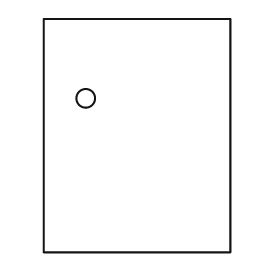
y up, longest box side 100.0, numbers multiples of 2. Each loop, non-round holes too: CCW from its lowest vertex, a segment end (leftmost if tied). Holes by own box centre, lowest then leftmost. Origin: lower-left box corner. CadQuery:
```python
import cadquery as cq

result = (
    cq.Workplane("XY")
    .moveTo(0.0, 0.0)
    .lineTo(80.0, 0.0)
    .lineTo(80.0, 100.0)
    .lineTo(0.0, 100.0)
    .close()
    .moveTo(18.0, 66.0)
    .circle(4.0)
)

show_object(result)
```